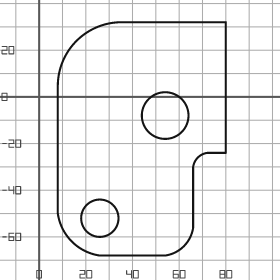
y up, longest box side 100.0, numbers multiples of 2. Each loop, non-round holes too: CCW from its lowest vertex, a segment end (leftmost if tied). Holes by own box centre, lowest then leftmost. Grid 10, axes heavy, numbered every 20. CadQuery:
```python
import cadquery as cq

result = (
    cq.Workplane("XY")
    .moveTo(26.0, -68.0)
    .lineTo(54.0, -68.0)
    .threePointArc((62.0, -64.0), (66.0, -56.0))
    .lineTo(66.0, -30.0)
    .threePointArc((68.0, -26.0), (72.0, -24.0))
    .lineTo(80.0, -24.0)
    .lineTo(80.0, 32.0)
    .lineTo(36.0, 32.0)
    .threePointArc((16.0, 24.0), (8.0, 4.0))
    .lineTo(8.0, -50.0)
    .threePointArc((14.0, -62.0), (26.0, -68.0))
    .close()
    .moveTo(26.0, -52.0)
    .circle(8.0)
    .moveTo(54.0, -8.0)
    .circle(10.0)
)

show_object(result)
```